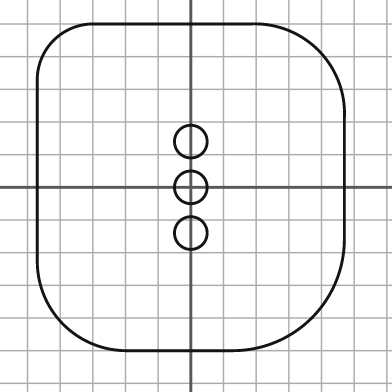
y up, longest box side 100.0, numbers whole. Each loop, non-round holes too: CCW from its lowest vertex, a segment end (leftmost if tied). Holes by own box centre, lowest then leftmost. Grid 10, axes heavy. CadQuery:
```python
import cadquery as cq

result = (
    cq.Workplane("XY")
    .moveTo(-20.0, -50.0)
    .lineTo(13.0, -50.0)
    .threePointArc((37.0, -40.0), (47.0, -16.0))
    .lineTo(47.0, 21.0)
    .threePointArc((39.0, 42.0), (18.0, 50.0))
    .lineTo(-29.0, 50.0)
    .threePointArc((-42.0, 45.0), (-47.0, 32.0))
    .lineTo(-47.0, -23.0)
    .threePointArc((-39.0, -42.0), (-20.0, -50.0))
    .close()
    .moveTo(0.0, -14.0)
    .circle(5.0)
    .moveTo(0.0, 0.0)
    .circle(5.0)
    .moveTo(0.0, 14.0)
    .circle(5.0)
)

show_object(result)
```